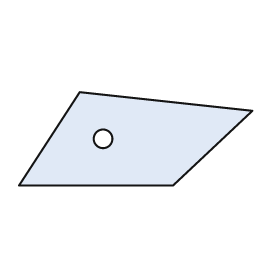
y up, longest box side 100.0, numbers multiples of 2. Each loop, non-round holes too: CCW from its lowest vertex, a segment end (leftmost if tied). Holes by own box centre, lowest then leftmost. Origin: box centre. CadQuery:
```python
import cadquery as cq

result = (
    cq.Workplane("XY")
    .moveTo(-50.0, -20.0)
    .lineTo(16.0, -20.0)
    .lineTo(50.0, 12.0)
    .lineTo(-24.0, 20.0)
    .close()
    .moveTo(-14.0, 0.0)
    .circle(4.0)
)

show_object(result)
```